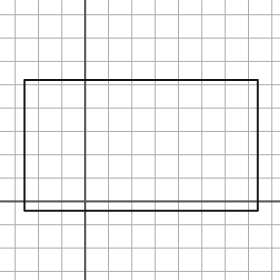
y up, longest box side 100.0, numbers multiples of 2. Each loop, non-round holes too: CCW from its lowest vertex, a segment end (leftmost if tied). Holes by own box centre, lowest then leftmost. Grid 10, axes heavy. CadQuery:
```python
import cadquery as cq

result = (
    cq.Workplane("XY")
    .moveTo(-26.0, -4.0)
    .lineTo(74.0, -4.0)
    .lineTo(74.0, 52.0)
    .lineTo(-26.0, 52.0)
    .close()
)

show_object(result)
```